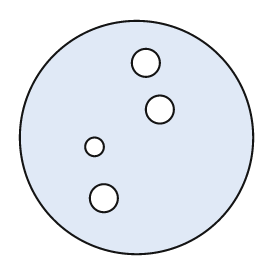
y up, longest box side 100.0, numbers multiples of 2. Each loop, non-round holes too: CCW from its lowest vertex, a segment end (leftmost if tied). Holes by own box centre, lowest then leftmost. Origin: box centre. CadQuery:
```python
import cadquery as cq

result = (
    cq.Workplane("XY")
    .moveTo(0.0, 0.0)
    .circle(50.0)
    .moveTo(-14.0, -26.0)
    .circle(6.0)
    .moveTo(-18.0, -4.0)
    .circle(4.0)
    .moveTo(10.0, 12.0)
    .circle(6.0)
    .moveTo(4.0, 32.0)
    .circle(6.0)
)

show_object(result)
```